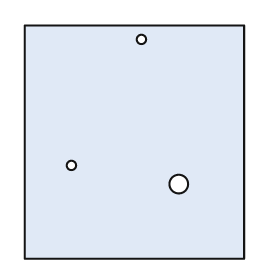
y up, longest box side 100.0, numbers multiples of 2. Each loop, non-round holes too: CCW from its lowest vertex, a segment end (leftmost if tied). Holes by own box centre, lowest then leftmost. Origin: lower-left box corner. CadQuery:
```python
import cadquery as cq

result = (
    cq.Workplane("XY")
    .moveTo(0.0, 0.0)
    .lineTo(94.0, 0.0)
    .lineTo(94.0, 100.0)
    .lineTo(0.0, 100.0)
    .close()
    .moveTo(66.0, 32.0)
    .circle(4.0)
    .moveTo(20.0, 40.0)
    .circle(2.0)
    .moveTo(50.0, 94.0)
    .circle(2.0)
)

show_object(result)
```